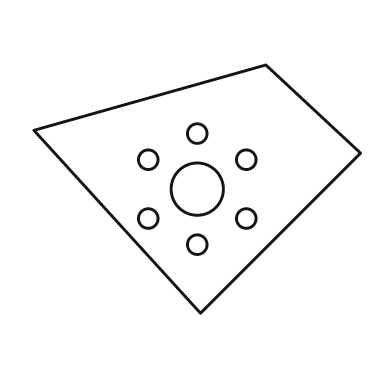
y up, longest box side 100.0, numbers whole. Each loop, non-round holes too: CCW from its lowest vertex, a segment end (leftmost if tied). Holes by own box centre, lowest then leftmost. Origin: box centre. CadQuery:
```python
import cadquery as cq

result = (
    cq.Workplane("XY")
    .moveTo(1.0, -38.0)
    .lineTo(50.0, 11.0)
    .lineTo(21.0, 38.0)
    .lineTo(-50.0, 18.0)
    .close()
    .moveTo(0.0, -17.0)
    .circle(3.0)
    .moveTo(-15.0, -9.0)
    .circle(3.0)
    .moveTo(15.0, -9.0)
    .circle(3.0)
    .moveTo(0.0, 0.0)
    .circle(8.0)
    .moveTo(-15.0, 9.0)
    .circle(3.0)
    .moveTo(15.0, 9.0)
    .circle(3.0)
    .moveTo(0.0, 17.0)
    .circle(3.0)
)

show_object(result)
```